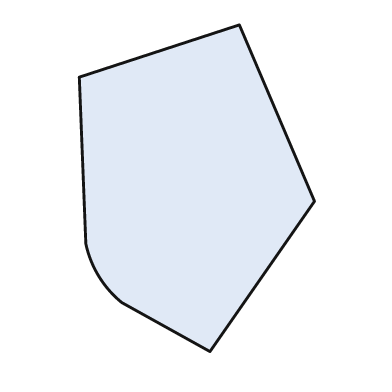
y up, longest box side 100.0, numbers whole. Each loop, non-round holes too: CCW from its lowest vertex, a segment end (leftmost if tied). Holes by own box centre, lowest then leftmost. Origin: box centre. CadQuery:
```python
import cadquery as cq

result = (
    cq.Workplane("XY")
    .moveTo(4.0, -50.0)
    .lineTo(36.0, -4.0)
    .lineTo(13.0, 50.0)
    .lineTo(-36.0, 34.0)
    .lineTo(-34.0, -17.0)
    .threePointArc((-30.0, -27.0), (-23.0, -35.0))
    .close()
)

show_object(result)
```